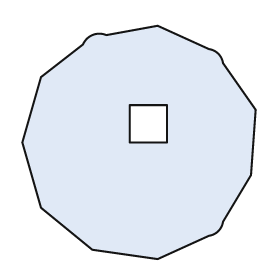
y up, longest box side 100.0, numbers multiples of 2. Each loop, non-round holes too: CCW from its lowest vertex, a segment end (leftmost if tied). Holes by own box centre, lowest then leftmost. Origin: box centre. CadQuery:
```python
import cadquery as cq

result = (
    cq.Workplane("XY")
    .moveTo(8.0, -50.0)
    .lineTo(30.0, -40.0)
    .threePointArc((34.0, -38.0), (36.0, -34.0))
    .lineTo(48.0, -14.0)
    .lineTo(50.0, 14.0)
    .lineTo(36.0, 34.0)
    .threePointArc((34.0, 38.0), (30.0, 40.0))
    .lineTo(8.0, 50.0)
    .lineTo(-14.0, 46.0)
    .threePointArc((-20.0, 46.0), (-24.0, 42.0))
    .lineTo(-42.0, 28.0)
    .lineTo(-50.0, 0.0)
    .lineTo(-42.0, -28.0)
    .lineTo(-20.0, -46.0)
    .close()
    .moveTo(-4.0, 0.0)
    .lineTo(12.0, 0.0)
    .lineTo(12.0, 16.0)
    .lineTo(-4.0, 16.0)
    .close()
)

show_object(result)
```